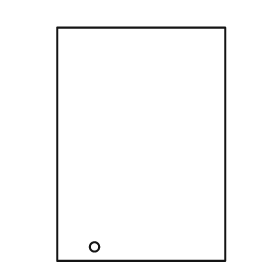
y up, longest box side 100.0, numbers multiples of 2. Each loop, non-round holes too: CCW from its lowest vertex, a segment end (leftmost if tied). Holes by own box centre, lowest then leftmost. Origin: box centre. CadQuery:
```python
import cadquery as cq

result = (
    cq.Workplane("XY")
    .moveTo(-36.0, -50.0)
    .lineTo(36.0, -50.0)
    .lineTo(36.0, 50.0)
    .lineTo(-36.0, 50.0)
    .close()
    .moveTo(-20.0, -44.0)
    .circle(2.0)
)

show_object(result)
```